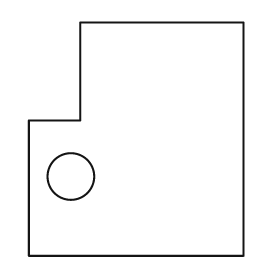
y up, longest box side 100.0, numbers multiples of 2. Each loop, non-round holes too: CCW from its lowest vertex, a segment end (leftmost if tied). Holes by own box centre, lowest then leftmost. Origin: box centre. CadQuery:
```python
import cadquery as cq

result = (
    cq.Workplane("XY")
    .moveTo(-46.0, -50.0)
    .lineTo(46.0, -50.0)
    .lineTo(46.0, 50.0)
    .lineTo(-24.0, 50.0)
    .lineTo(-24.0, 8.0)
    .lineTo(-46.0, 8.0)
    .close()
    .moveTo(-28.0, -16.0)
    .circle(10.0)
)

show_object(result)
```